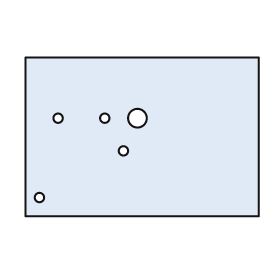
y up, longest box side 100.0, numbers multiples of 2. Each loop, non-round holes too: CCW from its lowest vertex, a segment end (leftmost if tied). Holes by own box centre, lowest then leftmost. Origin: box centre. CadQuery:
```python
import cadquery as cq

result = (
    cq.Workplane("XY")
    .moveTo(-50.0, -34.0)
    .lineTo(50.0, -34.0)
    .lineTo(50.0, 34.0)
    .lineTo(-50.0, 34.0)
    .close()
    .moveTo(-44.0, -26.0)
    .circle(2.0)
    .moveTo(-8.0, -6.0)
    .circle(2.0)
    .moveTo(-36.0, 8.0)
    .circle(2.0)
    .moveTo(-16.0, 8.0)
    .circle(2.0)
    .moveTo(-2.0, 8.0)
    .circle(4.0)
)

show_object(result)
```